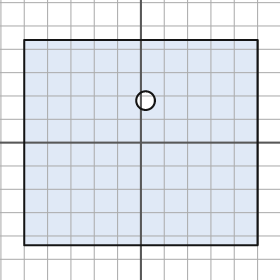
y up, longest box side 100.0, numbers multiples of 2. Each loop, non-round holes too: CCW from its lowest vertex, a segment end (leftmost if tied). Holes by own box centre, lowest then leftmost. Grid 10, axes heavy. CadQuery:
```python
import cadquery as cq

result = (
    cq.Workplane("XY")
    .moveTo(-50.0, -44.0)
    .lineTo(50.0, -44.0)
    .lineTo(50.0, 44.0)
    .lineTo(-50.0, 44.0)
    .close()
    .moveTo(2.0, 18.0)
    .circle(4.0)
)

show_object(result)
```